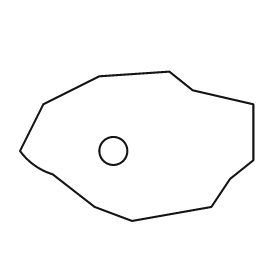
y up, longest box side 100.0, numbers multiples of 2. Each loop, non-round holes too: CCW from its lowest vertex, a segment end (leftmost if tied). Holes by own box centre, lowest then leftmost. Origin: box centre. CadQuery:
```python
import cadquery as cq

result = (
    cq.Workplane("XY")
    .moveTo(-2.0, -32.0)
    .lineTo(32.0, -26.0)
    .lineTo(40.0, -14.0)
    .lineTo(50.0, -6.0)
    .lineTo(50.0, 18.0)
    .lineTo(24.0, 24.0)
    .lineTo(14.0, 32.0)
    .lineTo(-16.0, 30.0)
    .lineTo(-40.0, 18.0)
    .lineTo(-50.0, -2.0)
    .threePointArc((-44.0, -8.0), (-36.0, -12.0))
    .lineTo(-18.0, -26.0)
    .close()
    .moveTo(-10.0, -2.0)
    .circle(6.0)
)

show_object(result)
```